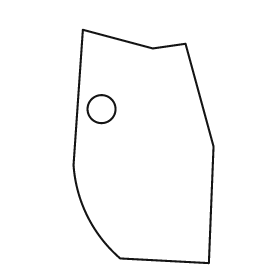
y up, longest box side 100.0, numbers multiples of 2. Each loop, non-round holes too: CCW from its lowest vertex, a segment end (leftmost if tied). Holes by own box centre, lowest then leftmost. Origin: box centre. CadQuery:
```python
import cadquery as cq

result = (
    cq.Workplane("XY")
    .moveTo(28.0, -50.0)
    .lineTo(30.0, 0.0)
    .lineTo(18.0, 44.0)
    .lineTo(4.0, 42.0)
    .lineTo(-26.0, 50.0)
    .lineTo(-30.0, -8.0)
    .threePointArc((-24.0, -30.0), (-10.0, -48.0))
    .close()
    .moveTo(-18.0, 16.0)
    .circle(6.0)
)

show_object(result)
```